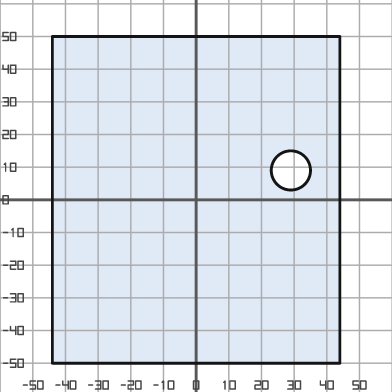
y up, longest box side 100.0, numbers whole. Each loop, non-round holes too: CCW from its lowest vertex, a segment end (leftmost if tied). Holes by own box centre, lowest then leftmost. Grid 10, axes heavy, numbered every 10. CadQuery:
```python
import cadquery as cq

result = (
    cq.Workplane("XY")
    .moveTo(-44.0, -50.0)
    .lineTo(44.0, -50.0)
    .lineTo(44.0, 50.0)
    .lineTo(-44.0, 50.0)
    .close()
    .moveTo(29.0, 9.0)
    .circle(6.0)
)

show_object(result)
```